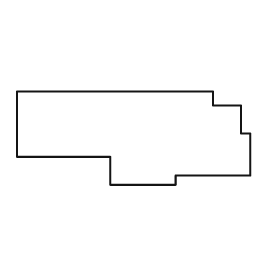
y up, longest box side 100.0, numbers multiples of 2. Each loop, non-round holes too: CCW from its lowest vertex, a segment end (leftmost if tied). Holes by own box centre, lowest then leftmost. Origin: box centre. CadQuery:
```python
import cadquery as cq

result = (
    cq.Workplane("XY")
    .moveTo(-10.0, -20.0)
    .lineTo(18.0, -20.0)
    .lineTo(18.0, -16.0)
    .lineTo(50.0, -16.0)
    .lineTo(50.0, 2.0)
    .lineTo(46.0, 2.0)
    .lineTo(46.0, 14.0)
    .lineTo(34.0, 14.0)
    .lineTo(34.0, 20.0)
    .lineTo(-50.0, 20.0)
    .lineTo(-50.0, -8.0)
    .lineTo(-10.0, -8.0)
    .close()
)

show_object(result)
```